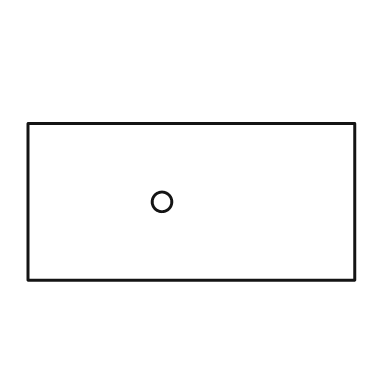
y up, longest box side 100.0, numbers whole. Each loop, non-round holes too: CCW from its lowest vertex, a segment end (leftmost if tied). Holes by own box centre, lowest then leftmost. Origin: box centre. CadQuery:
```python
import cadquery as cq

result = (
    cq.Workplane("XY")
    .moveTo(-50.0, -24.0)
    .lineTo(50.0, -24.0)
    .lineTo(50.0, 24.0)
    .lineTo(-50.0, 24.0)
    .close()
    .moveTo(-9.0, 0.0)
    .circle(3.0)
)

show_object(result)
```